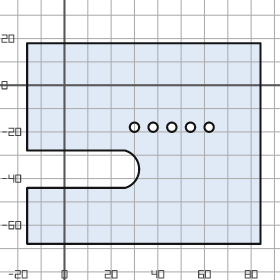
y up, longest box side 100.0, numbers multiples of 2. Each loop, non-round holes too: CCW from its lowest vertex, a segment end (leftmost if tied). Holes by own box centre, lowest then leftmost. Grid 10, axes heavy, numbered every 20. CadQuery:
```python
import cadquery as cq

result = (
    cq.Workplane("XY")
    .moveTo(-16.0, -68.0)
    .lineTo(84.0, -68.0)
    .lineTo(84.0, 18.0)
    .lineTo(-16.0, 18.0)
    .lineTo(-16.0, -28.0)
    .lineTo(26.0, -28.0)
    .threePointArc((32.0, -36.0), (26.0, -44.0))
    .lineTo(-16.0, -44.0)
    .close()
    .moveTo(30.0, -18.0)
    .circle(2.0)
    .moveTo(38.0, -18.0)
    .circle(2.0)
    .moveTo(46.0, -18.0)
    .circle(2.0)
    .moveTo(54.0, -18.0)
    .circle(2.0)
    .moveTo(62.0, -18.0)
    .circle(2.0)
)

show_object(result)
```